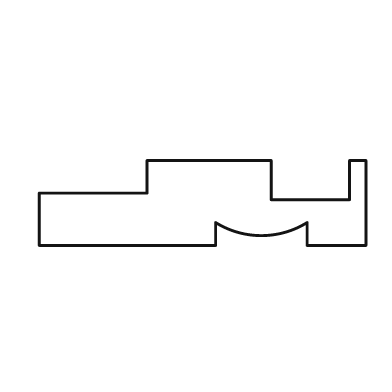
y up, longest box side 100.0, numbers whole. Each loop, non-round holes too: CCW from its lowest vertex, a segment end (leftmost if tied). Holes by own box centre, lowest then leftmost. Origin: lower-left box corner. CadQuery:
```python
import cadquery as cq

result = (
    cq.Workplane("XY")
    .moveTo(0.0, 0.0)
    .lineTo(54.0, 0.0)
    .lineTo(54.0, 7.0)
    .threePointArc((68.0, 3.0), (82.0, 7.0))
    .lineTo(82.0, 0.0)
    .lineTo(100.0, 0.0)
    .lineTo(100.0, 26.0)
    .lineTo(95.0, 26.0)
    .lineTo(95.0, 14.0)
    .lineTo(71.0, 14.0)
    .lineTo(71.0, 26.0)
    .lineTo(33.0, 26.0)
    .lineTo(33.0, 16.0)
    .lineTo(0.0, 16.0)
    .close()
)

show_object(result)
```